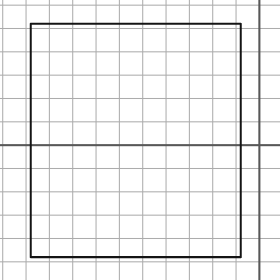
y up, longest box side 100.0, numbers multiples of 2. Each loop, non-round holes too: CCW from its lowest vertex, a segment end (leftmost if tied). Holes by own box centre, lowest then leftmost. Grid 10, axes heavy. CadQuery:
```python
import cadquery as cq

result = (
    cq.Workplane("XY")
    .moveTo(-98.0, -48.0)
    .lineTo(-8.0, -48.0)
    .lineTo(-8.0, 52.0)
    .lineTo(-98.0, 52.0)
    .close()
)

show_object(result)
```